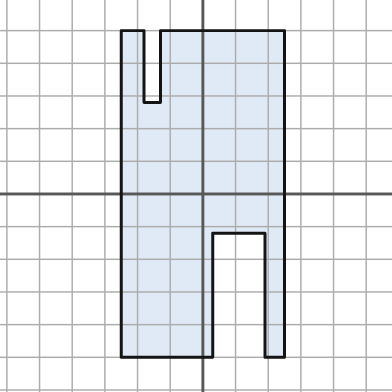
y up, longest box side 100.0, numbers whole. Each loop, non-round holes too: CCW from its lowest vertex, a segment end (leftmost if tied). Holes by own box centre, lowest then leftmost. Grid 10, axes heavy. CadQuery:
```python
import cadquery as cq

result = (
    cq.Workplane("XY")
    .moveTo(-25.0, -50.0)
    .lineTo(3.0, -50.0)
    .lineTo(3.0, -12.0)
    .lineTo(19.0, -12.0)
    .lineTo(19.0, -50.0)
    .lineTo(25.0, -50.0)
    .lineTo(25.0, 50.0)
    .lineTo(-13.0, 50.0)
    .lineTo(-13.0, 28.0)
    .lineTo(-18.0, 28.0)
    .lineTo(-18.0, 50.0)
    .lineTo(-25.0, 50.0)
    .close()
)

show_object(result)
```